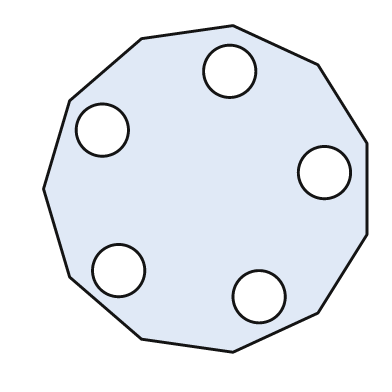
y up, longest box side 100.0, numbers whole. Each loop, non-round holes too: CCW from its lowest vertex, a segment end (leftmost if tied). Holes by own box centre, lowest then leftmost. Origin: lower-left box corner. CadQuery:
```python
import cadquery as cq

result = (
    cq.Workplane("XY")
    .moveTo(58.0, 0.0)
    .lineTo(84.0, 12.0)
    .lineTo(99.0, 36.0)
    .lineTo(99.0, 64.0)
    .lineTo(84.0, 88.0)
    .lineTo(58.0, 100.0)
    .lineTo(30.0, 96.0)
    .lineTo(8.0, 77.0)
    .lineTo(0.0, 50.0)
    .lineTo(8.0, 23.0)
    .lineTo(30.0, 4.0)
    .close()
    .moveTo(66.0, 17.0)
    .circle(8.0)
    .moveTo(23.0, 25.0)
    .circle(8.0)
    .moveTo(86.0, 55.0)
    .circle(8.0)
    .moveTo(18.0, 68.0)
    .circle(8.0)
    .moveTo(57.0, 86.0)
    .circle(8.0)
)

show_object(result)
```